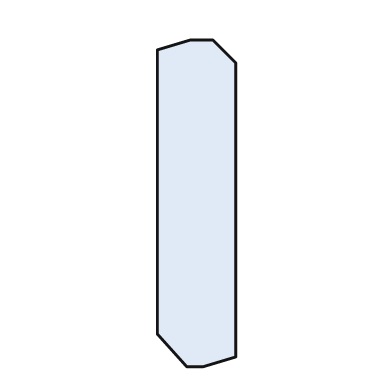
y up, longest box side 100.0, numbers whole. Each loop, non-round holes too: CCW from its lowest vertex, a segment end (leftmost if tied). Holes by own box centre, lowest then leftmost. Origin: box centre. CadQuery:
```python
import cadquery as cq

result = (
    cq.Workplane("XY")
    .moveTo(-3.0, -50.0)
    .lineTo(2.0, -50.0)
    .lineTo(12.0, -47.0)
    .lineTo(12.0, 43.0)
    .lineTo(5.0, 50.0)
    .lineTo(-2.0, 50.0)
    .lineTo(-12.0, 47.0)
    .lineTo(-12.0, -40.0)
    .close()
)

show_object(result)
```